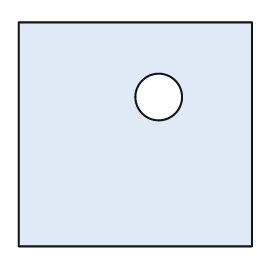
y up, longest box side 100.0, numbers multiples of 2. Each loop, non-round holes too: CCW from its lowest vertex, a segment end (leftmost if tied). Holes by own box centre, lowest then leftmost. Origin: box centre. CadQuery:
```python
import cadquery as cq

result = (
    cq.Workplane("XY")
    .moveTo(-50.0, -48.0)
    .lineTo(50.0, -48.0)
    .lineTo(50.0, 48.0)
    .lineTo(-50.0, 48.0)
    .close()
    .moveTo(10.0, 16.0)
    .circle(10.0)
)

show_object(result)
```